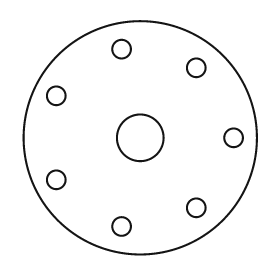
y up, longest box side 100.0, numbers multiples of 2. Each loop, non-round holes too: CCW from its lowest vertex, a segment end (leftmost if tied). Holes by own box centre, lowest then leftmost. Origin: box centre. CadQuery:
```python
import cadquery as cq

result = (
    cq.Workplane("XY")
    .moveTo(0.0, 0.0)
    .circle(50.0)
    .moveTo(-8.0, -38.0)
    .circle(4.0)
    .moveTo(24.0, -30.0)
    .circle(4.0)
    .moveTo(-36.0, -18.0)
    .circle(4.0)
    .moveTo(0.0, 0.0)
    .circle(10.0)
    .moveTo(40.0, 0.0)
    .circle(4.0)
    .moveTo(-36.0, 18.0)
    .circle(4.0)
    .moveTo(24.0, 30.0)
    .circle(4.0)
    .moveTo(-8.0, 38.0)
    .circle(4.0)
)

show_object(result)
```